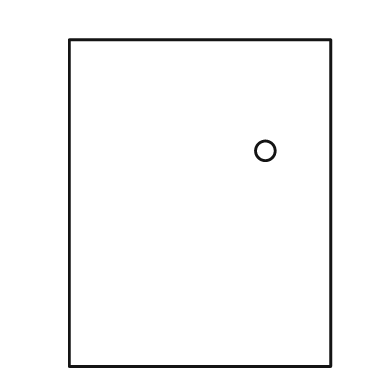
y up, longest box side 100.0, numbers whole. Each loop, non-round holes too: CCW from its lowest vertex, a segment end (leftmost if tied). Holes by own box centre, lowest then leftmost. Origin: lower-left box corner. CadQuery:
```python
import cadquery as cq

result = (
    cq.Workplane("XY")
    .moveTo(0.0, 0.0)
    .lineTo(80.0, 0.0)
    .lineTo(80.0, 100.0)
    .lineTo(0.0, 100.0)
    .close()
    .moveTo(60.0, 66.0)
    .circle(3.0)
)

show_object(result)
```